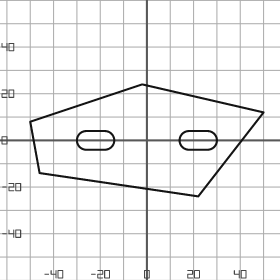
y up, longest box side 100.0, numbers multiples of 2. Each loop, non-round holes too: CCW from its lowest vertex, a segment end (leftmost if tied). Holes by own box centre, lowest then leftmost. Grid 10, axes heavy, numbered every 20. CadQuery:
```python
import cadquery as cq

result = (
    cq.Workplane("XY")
    .moveTo(22.0, -24.0)
    .lineTo(50.0, 12.0)
    .lineTo(-2.0, 24.0)
    .lineTo(-50.0, 8.0)
    .lineTo(-46.0, -14.0)
    .close()
    .moveTo(-26.0, -4.0)
    .lineTo(-18.0, -4.0)
    .threePointArc((-14.0, 0.0), (-18.0, 4.0))
    .lineTo(-26.0, 4.0)
    .threePointArc((-30.0, 0.0), (-26.0, -4.0))
    .close()
    .moveTo(18.0, -4.0)
    .lineTo(26.0, -4.0)
    .threePointArc((30.0, 0.0), (26.0, 4.0))
    .lineTo(18.0, 4.0)
    .threePointArc((14.0, 0.0), (18.0, -4.0))
    .close()
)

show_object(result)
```